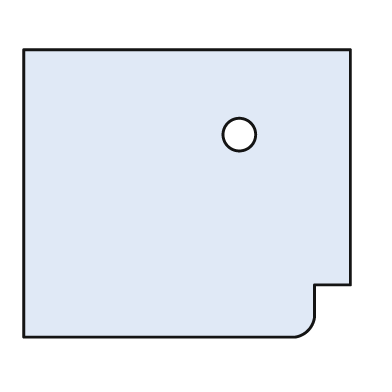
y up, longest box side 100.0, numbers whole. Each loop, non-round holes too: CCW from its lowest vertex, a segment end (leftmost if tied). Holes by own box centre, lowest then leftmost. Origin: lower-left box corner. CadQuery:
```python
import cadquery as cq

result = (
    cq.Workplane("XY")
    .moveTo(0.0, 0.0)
    .lineTo(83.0, 0.0)
    .threePointArc((87.0, 2.0), (89.0, 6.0))
    .lineTo(89.0, 16.0)
    .lineTo(100.0, 16.0)
    .lineTo(100.0, 88.0)
    .lineTo(0.0, 88.0)
    .close()
    .moveTo(66.0, 62.0)
    .circle(5.0)
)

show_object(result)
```